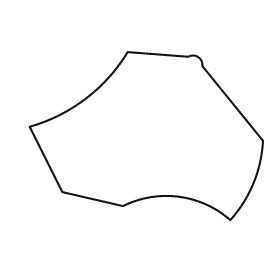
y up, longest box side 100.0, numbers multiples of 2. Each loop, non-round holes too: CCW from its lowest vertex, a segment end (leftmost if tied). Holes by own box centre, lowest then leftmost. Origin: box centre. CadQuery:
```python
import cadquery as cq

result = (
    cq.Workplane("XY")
    .moveTo(36.0, -36.0)
    .threePointArc((46.0, -20.0), (50.0, -2.0))
    .lineTo(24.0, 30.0)
    .threePointArc((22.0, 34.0), (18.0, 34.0))
    .lineTo(-8.0, 36.0)
    .threePointArc((-26.0, 16.0), (-50.0, 4.0))
    .lineTo(-36.0, -24.0)
    .lineTo(-10.0, -30.0)
    .threePointArc((14.0, -26.0), (36.0, -36.0))
    .close()
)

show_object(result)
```